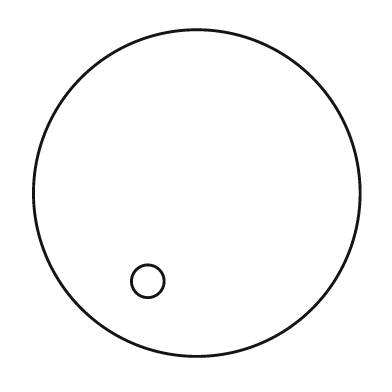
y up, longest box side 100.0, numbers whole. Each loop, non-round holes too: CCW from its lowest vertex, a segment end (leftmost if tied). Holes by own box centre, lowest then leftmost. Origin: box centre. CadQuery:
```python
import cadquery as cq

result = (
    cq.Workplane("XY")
    .moveTo(0.0, 0.0)
    .circle(50.0)
    .moveTo(-15.0, -27.0)
    .circle(5.0)
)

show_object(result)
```